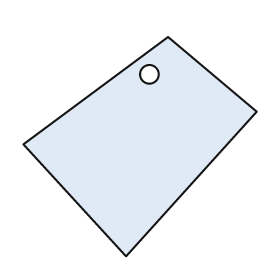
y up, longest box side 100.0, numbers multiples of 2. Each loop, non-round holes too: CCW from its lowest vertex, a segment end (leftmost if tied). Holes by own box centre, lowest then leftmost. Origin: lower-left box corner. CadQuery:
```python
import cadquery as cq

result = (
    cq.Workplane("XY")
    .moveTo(44.0, 0.0)
    .lineTo(100.0, 62.0)
    .lineTo(62.0, 94.0)
    .lineTo(0.0, 48.0)
    .close()
    .moveTo(54.0, 78.0)
    .circle(4.0)
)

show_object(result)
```